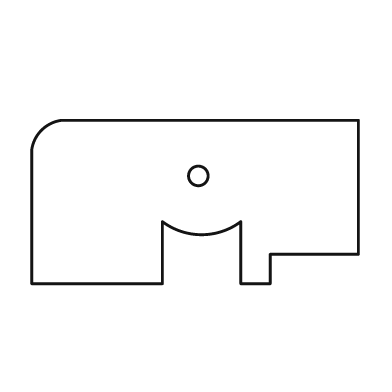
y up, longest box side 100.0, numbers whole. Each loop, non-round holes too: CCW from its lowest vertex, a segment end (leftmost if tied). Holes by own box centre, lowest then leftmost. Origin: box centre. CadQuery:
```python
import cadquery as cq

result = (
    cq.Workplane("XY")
    .moveTo(-50.0, -25.0)
    .lineTo(-10.0, -25.0)
    .lineTo(-10.0, -6.0)
    .threePointArc((2.0, -10.0), (14.0, -6.0))
    .lineTo(14.0, -25.0)
    .lineTo(23.0, -25.0)
    .lineTo(23.0, -16.0)
    .lineTo(50.0, -16.0)
    .lineTo(50.0, 25.0)
    .lineTo(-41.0, 25.0)
    .threePointArc((-47.0, 22.0), (-50.0, 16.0))
    .close()
    .moveTo(1.0, 8.0)
    .circle(3.0)
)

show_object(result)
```